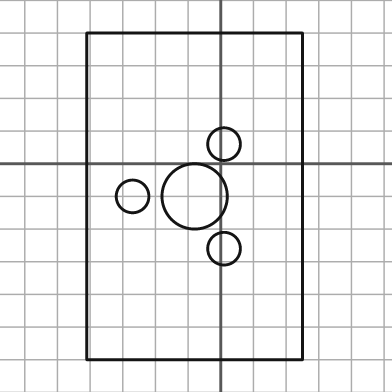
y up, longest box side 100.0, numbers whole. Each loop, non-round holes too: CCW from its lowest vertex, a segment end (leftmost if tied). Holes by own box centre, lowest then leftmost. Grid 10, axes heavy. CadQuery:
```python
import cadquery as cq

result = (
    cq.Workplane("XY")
    .moveTo(-41.0, -60.0)
    .lineTo(25.0, -60.0)
    .lineTo(25.0, 40.0)
    .lineTo(-41.0, 40.0)
    .close()
    .moveTo(1.0, -26.0)
    .circle(5.0)
    .moveTo(-27.0, -10.0)
    .circle(5.0)
    .moveTo(-8.0, -10.0)
    .circle(10.0)
    .moveTo(1.0, 6.0)
    .circle(5.0)
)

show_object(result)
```